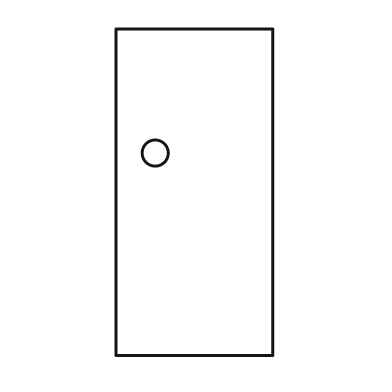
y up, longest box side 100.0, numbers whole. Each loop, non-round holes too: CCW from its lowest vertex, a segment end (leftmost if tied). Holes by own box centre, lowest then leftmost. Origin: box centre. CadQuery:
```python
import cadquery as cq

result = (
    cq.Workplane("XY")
    .moveTo(-24.0, -50.0)
    .lineTo(24.0, -50.0)
    .lineTo(24.0, 50.0)
    .lineTo(-24.0, 50.0)
    .close()
    .moveTo(-12.0, 12.0)
    .circle(4.0)
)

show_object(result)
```